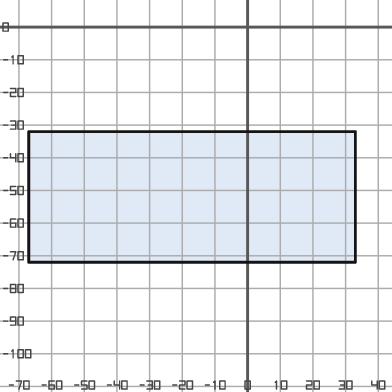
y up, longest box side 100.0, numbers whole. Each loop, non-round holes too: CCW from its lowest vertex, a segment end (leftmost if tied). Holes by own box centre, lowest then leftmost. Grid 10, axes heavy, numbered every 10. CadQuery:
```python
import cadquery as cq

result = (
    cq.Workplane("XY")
    .moveTo(-67.0, -72.0)
    .lineTo(33.0, -72.0)
    .lineTo(33.0, -32.0)
    .lineTo(-67.0, -32.0)
    .close()
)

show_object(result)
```